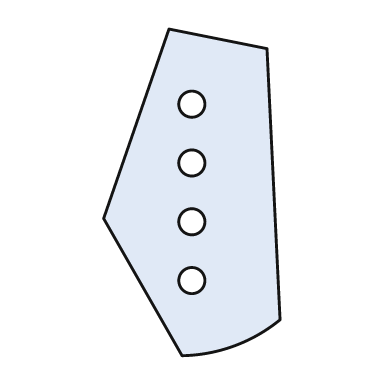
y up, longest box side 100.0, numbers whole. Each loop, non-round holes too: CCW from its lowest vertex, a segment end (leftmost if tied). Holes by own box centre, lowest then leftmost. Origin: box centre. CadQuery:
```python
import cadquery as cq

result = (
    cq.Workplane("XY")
    .moveTo(-3.0, -50.0)
    .threePointArc((13.0, -47.0), (27.0, -39.0))
    .lineTo(23.0, 44.0)
    .lineTo(-7.0, 50.0)
    .lineTo(-27.0, -8.0)
    .close()
    .moveTo(0.0, -27.0)
    .circle(4.0)
    .moveTo(0.0, -9.0)
    .circle(4.0)
    .moveTo(0.0, 9.0)
    .circle(4.0)
    .moveTo(0.0, 27.0)
    .circle(4.0)
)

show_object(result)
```